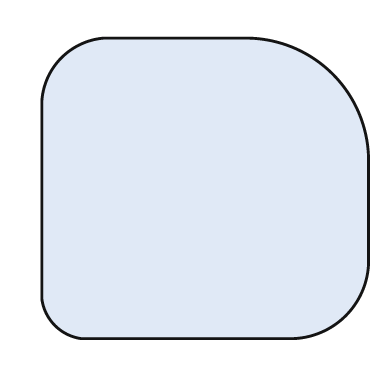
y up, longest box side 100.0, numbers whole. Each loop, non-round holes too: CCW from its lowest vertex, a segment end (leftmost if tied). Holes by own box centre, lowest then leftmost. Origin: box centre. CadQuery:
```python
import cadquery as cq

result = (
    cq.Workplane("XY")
    .moveTo(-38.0, -46.0)
    .lineTo(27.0, -46.0)
    .threePointArc((43.0, -39.0), (50.0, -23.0))
    .lineTo(50.0, 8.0)
    .threePointArc((39.0, 35.0), (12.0, 46.0))
    .lineTo(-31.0, 46.0)
    .threePointArc((-44.0, 40.0), (-50.0, 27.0))
    .lineTo(-50.0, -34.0)
    .threePointArc((-46.0, -42.0), (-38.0, -46.0))
    .close()
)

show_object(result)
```